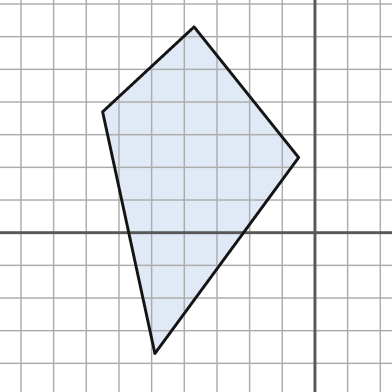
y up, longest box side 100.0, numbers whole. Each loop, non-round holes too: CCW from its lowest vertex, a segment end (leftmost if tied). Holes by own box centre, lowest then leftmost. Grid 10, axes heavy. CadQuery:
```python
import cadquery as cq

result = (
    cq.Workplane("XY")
    .moveTo(-49.0, -37.0)
    .lineTo(-5.0, 23.0)
    .lineTo(-37.0, 63.0)
    .lineTo(-65.0, 37.0)
    .close()
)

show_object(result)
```